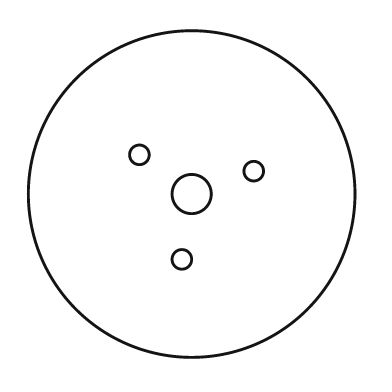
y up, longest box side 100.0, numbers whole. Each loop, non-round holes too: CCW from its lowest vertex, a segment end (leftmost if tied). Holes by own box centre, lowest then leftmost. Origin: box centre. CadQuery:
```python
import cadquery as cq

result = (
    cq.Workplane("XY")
    .moveTo(0.0, 0.0)
    .circle(50.0)
    .moveTo(-3.0, -20.0)
    .circle(3.0)
    .moveTo(0.0, 0.0)
    .circle(6.0)
    .moveTo(19.0, 7.0)
    .circle(3.0)
    .moveTo(-16.0, 12.0)
    .circle(3.0)
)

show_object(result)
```